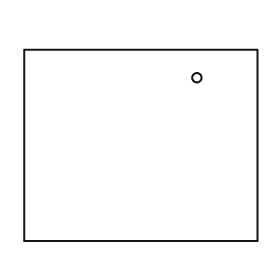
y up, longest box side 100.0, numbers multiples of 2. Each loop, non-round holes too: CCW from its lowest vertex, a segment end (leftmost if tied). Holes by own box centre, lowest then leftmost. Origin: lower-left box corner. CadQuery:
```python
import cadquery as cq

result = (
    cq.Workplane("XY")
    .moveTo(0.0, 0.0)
    .lineTo(100.0, 0.0)
    .lineTo(100.0, 82.0)
    .lineTo(0.0, 82.0)
    .close()
    .moveTo(74.0, 70.0)
    .circle(2.0)
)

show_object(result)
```